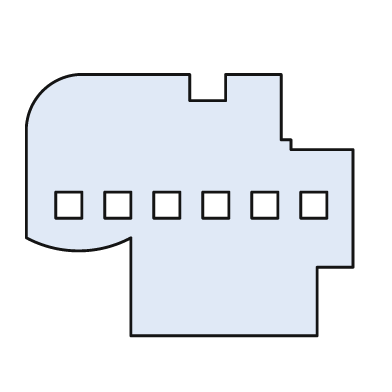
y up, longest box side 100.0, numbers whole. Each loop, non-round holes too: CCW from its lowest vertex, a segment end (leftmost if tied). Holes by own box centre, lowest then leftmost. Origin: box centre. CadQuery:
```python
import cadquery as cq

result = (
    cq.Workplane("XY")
    .moveTo(-18.0, -40.0)
    .lineTo(39.0, -40.0)
    .lineTo(39.0, -19.0)
    .lineTo(50.0, -19.0)
    .lineTo(50.0, 17.0)
    .lineTo(31.0, 17.0)
    .lineTo(31.0, 20.0)
    .lineTo(28.0, 20.0)
    .lineTo(28.0, 40.0)
    .lineTo(11.0, 40.0)
    .lineTo(11.0, 32.0)
    .lineTo(0.0, 32.0)
    .lineTo(0.0, 40.0)
    .lineTo(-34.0, 40.0)
    .threePointArc((-45.0, 35.0), (-50.0, 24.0))
    .lineTo(-50.0, -10.0)
    .threePointArc((-34.0, -14.0), (-18.0, -10.0))
    .close()
    .moveTo(-41.0, -4.0)
    .lineTo(-33.0, -4.0)
    .lineTo(-33.0, 4.0)
    .lineTo(-41.0, 4.0)
    .close()
    .moveTo(-26.0, -4.0)
    .lineTo(-18.0, -4.0)
    .lineTo(-18.0, 4.0)
    .lineTo(-26.0, 4.0)
    .close()
    .moveTo(-11.0, -4.0)
    .lineTo(-3.0, -4.0)
    .lineTo(-3.0, 4.0)
    .lineTo(-11.0, 4.0)
    .close()
    .moveTo(4.0, -4.0)
    .lineTo(12.0, -4.0)
    .lineTo(12.0, 4.0)
    .lineTo(4.0, 4.0)
    .close()
    .moveTo(19.0, -4.0)
    .lineTo(27.0, -4.0)
    .lineTo(27.0, 4.0)
    .lineTo(19.0, 4.0)
    .close()
    .moveTo(34.0, -4.0)
    .lineTo(42.0, -4.0)
    .lineTo(42.0, 4.0)
    .lineTo(34.0, 4.0)
    .close()
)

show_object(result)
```